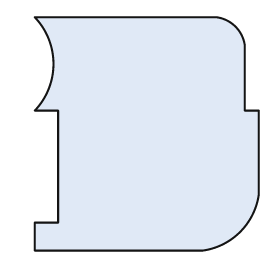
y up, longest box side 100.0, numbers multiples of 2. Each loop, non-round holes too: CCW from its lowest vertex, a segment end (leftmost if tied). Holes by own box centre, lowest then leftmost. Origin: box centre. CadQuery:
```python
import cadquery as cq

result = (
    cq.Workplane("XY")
    .moveTo(-48.0, -50.0)
    .lineTo(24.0, -50.0)
    .threePointArc((40.0, -42.0), (48.0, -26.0))
    .lineTo(48.0, 10.0)
    .lineTo(42.0, 10.0)
    .lineTo(42.0, 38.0)
    .threePointArc((38.0, 46.0), (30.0, 50.0))
    .lineTo(-48.0, 50.0)
    .threePointArc((-40.0, 30.0), (-48.0, 10.0))
    .lineTo(-38.0, 10.0)
    .lineTo(-38.0, -38.0)
    .lineTo(-48.0, -38.0)
    .close()
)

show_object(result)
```